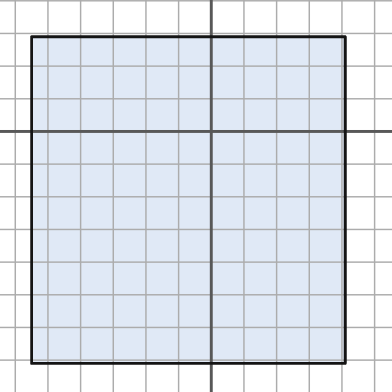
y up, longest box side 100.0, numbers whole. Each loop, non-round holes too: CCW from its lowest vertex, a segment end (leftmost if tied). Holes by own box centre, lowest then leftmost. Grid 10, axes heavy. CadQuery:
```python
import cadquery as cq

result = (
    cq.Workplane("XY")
    .moveTo(-55.0, -71.0)
    .lineTo(41.0, -71.0)
    .lineTo(41.0, 29.0)
    .lineTo(-55.0, 29.0)
    .close()
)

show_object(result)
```